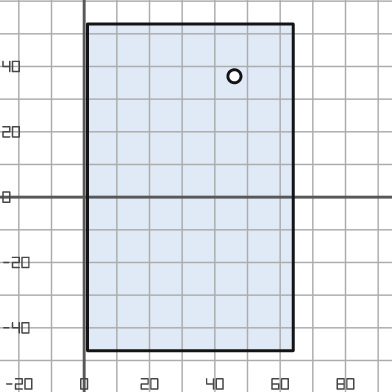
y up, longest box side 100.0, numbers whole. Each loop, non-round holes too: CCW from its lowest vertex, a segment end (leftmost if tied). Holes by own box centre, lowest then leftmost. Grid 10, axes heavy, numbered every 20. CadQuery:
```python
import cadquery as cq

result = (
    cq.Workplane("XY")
    .moveTo(1.0, -47.0)
    .lineTo(64.0, -47.0)
    .lineTo(64.0, 53.0)
    .lineTo(1.0, 53.0)
    .close()
    .moveTo(46.0, 37.0)
    .circle(2.0)
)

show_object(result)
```